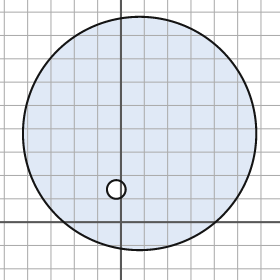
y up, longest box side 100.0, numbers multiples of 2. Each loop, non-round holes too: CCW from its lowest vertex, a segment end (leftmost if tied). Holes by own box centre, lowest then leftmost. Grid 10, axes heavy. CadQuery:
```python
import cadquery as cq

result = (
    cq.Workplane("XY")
    .moveTo(8.0, 38.0)
    .circle(50.0)
    .moveTo(-2.0, 14.0)
    .circle(4.0)
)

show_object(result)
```